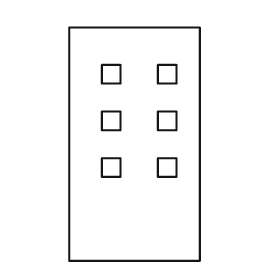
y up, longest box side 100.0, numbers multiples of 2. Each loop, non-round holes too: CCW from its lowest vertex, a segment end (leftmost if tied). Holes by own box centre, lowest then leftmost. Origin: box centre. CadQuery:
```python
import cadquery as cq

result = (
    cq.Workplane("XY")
    .moveTo(-28.0, -50.0)
    .lineTo(28.0, -50.0)
    .lineTo(28.0, 50.0)
    .lineTo(-28.0, 50.0)
    .close()
    .moveTo(-14.0, -14.0)
    .lineTo(-6.0, -14.0)
    .lineTo(-6.0, -6.0)
    .lineTo(-14.0, -6.0)
    .close()
    .moveTo(10.0, -14.0)
    .lineTo(18.0, -14.0)
    .lineTo(18.0, -6.0)
    .lineTo(10.0, -6.0)
    .close()
    .moveTo(-14.0, 6.0)
    .lineTo(-6.0, 6.0)
    .lineTo(-6.0, 14.0)
    .lineTo(-14.0, 14.0)
    .close()
    .moveTo(10.0, 6.0)
    .lineTo(18.0, 6.0)
    .lineTo(18.0, 14.0)
    .lineTo(10.0, 14.0)
    .close()
    .moveTo(-14.0, 26.0)
    .lineTo(-6.0, 26.0)
    .lineTo(-6.0, 34.0)
    .lineTo(-14.0, 34.0)
    .close()
    .moveTo(10.0, 26.0)
    .lineTo(18.0, 26.0)
    .lineTo(18.0, 34.0)
    .lineTo(10.0, 34.0)
    .close()
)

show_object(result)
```